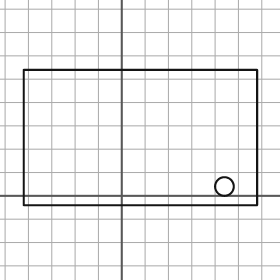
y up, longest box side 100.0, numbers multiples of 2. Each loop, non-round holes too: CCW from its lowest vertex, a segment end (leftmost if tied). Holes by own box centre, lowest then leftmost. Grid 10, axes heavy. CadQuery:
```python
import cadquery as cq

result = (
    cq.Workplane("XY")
    .moveTo(-42.0, -4.0)
    .lineTo(58.0, -4.0)
    .lineTo(58.0, 54.0)
    .lineTo(-42.0, 54.0)
    .close()
    .moveTo(44.0, 4.0)
    .circle(4.0)
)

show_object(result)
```